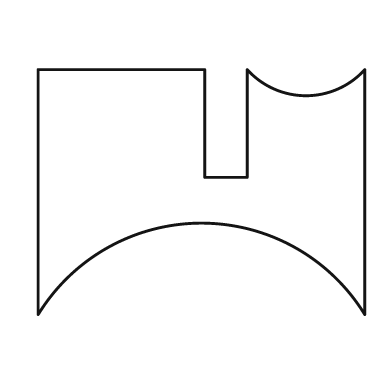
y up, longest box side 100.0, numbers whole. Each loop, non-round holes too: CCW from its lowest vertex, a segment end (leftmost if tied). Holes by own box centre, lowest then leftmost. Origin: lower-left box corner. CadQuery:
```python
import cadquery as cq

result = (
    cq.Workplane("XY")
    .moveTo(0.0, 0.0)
    .threePointArc((50.0, 28.0), (100.0, 0.0))
    .lineTo(100.0, 75.0)
    .threePointArc((82.0, 67.0), (64.0, 75.0))
    .lineTo(64.0, 42.0)
    .lineTo(51.0, 42.0)
    .lineTo(51.0, 75.0)
    .lineTo(0.0, 75.0)
    .close()
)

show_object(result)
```